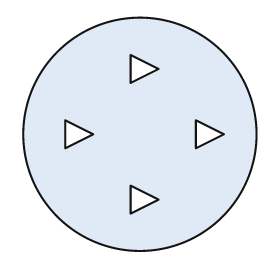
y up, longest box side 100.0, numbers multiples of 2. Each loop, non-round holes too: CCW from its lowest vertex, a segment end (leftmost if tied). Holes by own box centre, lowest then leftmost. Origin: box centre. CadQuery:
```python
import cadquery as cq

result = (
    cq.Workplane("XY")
    .moveTo(0.0, 0.0)
    .circle(50.0)
    .moveTo(-4.0, -34.0)
    .lineTo(8.0, -28.0)
    .lineTo(-4.0, -22.0)
    .close()
    .moveTo(-32.0, -6.0)
    .lineTo(-20.0, 0.0)
    .lineTo(-32.0, 6.0)
    .close()
    .moveTo(24.0, -6.0)
    .lineTo(36.0, 0.0)
    .lineTo(24.0, 6.0)
    .close()
    .moveTo(-4.0, 22.0)
    .lineTo(8.0, 28.0)
    .lineTo(-4.0, 34.0)
    .close()
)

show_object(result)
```